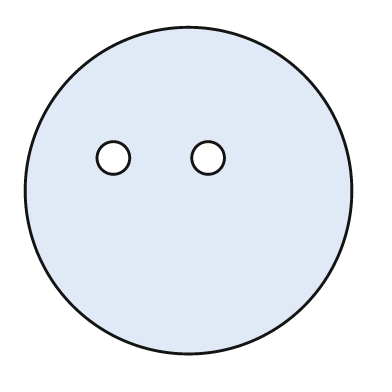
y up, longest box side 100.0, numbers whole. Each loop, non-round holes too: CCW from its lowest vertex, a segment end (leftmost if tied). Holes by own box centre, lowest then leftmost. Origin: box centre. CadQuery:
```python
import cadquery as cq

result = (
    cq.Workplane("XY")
    .moveTo(0.0, 0.0)
    .circle(50.0)
    .moveTo(-23.0, 10.0)
    .circle(5.0)
    .moveTo(6.0, 10.0)
    .circle(5.0)
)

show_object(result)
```